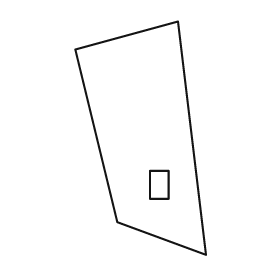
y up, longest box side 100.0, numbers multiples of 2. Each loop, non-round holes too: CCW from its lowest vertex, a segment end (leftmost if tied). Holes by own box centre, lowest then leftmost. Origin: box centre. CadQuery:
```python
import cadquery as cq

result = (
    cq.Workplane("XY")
    .moveTo(28.0, -50.0)
    .lineTo(16.0, 50.0)
    .lineTo(-28.0, 38.0)
    .lineTo(-10.0, -36.0)
    .close()
    .moveTo(4.0, -26.0)
    .lineTo(12.0, -26.0)
    .lineTo(12.0, -14.0)
    .lineTo(4.0, -14.0)
    .close()
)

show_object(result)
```